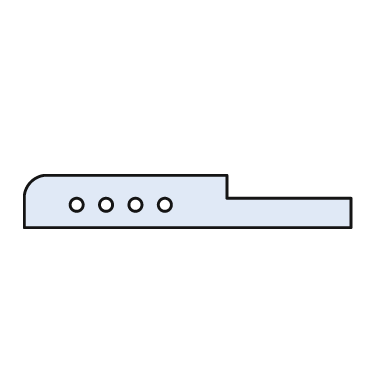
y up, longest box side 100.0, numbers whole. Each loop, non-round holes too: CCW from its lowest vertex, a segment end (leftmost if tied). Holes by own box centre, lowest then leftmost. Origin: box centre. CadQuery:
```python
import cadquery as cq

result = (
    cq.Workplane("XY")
    .moveTo(-50.0, -8.0)
    .lineTo(50.0, -8.0)
    .lineTo(50.0, 1.0)
    .lineTo(12.0, 1.0)
    .lineTo(12.0, 8.0)
    .lineTo(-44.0, 8.0)
    .threePointArc((-48.0, 6.0), (-50.0, 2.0))
    .close()
    .moveTo(-34.0, -1.0)
    .circle(2.0)
    .moveTo(-25.0, -1.0)
    .circle(2.0)
    .moveTo(-16.0, -1.0)
    .circle(2.0)
    .moveTo(-7.0, -1.0)
    .circle(2.0)
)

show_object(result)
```